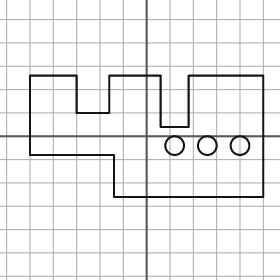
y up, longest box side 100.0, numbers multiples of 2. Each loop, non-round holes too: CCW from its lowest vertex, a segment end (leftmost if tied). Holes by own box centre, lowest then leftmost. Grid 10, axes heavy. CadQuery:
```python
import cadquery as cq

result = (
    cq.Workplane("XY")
    .moveTo(-14.0, -26.0)
    .lineTo(50.0, -26.0)
    .lineTo(50.0, 26.0)
    .lineTo(18.0, 26.0)
    .lineTo(18.0, 4.0)
    .lineTo(6.0, 4.0)
    .lineTo(6.0, 26.0)
    .lineTo(-16.0, 26.0)
    .lineTo(-16.0, 10.0)
    .lineTo(-30.0, 10.0)
    .lineTo(-30.0, 26.0)
    .lineTo(-50.0, 26.0)
    .lineTo(-50.0, -8.0)
    .lineTo(-14.0, -8.0)
    .close()
    .moveTo(12.0, -4.0)
    .circle(4.0)
    .moveTo(26.0, -4.0)
    .circle(4.0)
    .moveTo(40.0, -4.0)
    .circle(4.0)
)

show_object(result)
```